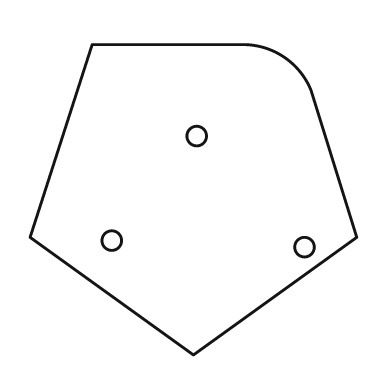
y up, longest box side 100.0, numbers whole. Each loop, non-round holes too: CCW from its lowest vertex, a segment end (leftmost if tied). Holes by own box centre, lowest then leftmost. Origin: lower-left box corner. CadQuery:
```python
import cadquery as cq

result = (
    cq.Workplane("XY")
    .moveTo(50.0, 0.0)
    .lineTo(100.0, 36.0)
    .lineTo(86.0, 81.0)
    .threePointArc((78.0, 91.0), (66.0, 95.0))
    .lineTo(19.0, 95.0)
    .lineTo(0.0, 36.0)
    .close()
    .moveTo(84.0, 33.0)
    .circle(3.0)
    .moveTo(25.0, 35.0)
    .circle(3.0)
    .moveTo(51.0, 67.0)
    .circle(3.0)
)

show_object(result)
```